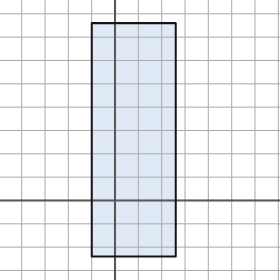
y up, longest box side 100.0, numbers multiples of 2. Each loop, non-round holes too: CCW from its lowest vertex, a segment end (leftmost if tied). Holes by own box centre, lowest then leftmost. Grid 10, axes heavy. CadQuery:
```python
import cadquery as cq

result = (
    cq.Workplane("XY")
    .moveTo(-10.0, -24.0)
    .lineTo(26.0, -24.0)
    .lineTo(26.0, 76.0)
    .lineTo(-10.0, 76.0)
    .close()
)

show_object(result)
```